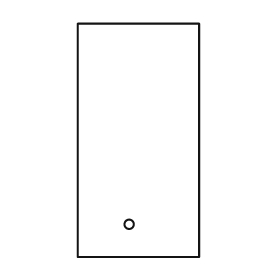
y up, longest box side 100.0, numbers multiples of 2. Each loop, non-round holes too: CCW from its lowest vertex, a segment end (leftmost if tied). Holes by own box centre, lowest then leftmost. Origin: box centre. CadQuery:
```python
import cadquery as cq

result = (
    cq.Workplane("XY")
    .moveTo(-26.0, -50.0)
    .lineTo(26.0, -50.0)
    .lineTo(26.0, 50.0)
    .lineTo(-26.0, 50.0)
    .close()
    .moveTo(-4.0, -36.0)
    .circle(2.0)
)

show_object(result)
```